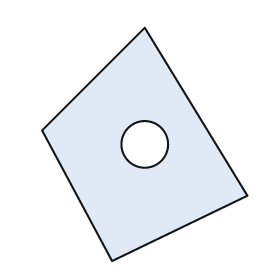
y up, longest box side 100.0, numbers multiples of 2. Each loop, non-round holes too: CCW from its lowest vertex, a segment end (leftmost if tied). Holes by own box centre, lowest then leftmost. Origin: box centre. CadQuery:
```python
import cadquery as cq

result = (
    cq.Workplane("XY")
    .moveTo(-14.0, -50.0)
    .lineTo(44.0, -22.0)
    .lineTo(0.0, 50.0)
    .lineTo(-44.0, 6.0)
    .close()
    .moveTo(0.0, 0.0)
    .circle(10.0)
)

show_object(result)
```